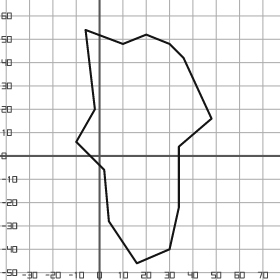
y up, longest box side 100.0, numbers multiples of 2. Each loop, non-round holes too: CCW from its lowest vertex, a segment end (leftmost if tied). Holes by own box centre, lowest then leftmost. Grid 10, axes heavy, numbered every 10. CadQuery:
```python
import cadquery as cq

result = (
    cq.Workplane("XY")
    .moveTo(16.0, -46.0)
    .lineTo(30.0, -40.0)
    .lineTo(34.0, -22.0)
    .lineTo(34.0, 4.0)
    .lineTo(48.0, 16.0)
    .lineTo(36.0, 42.0)
    .lineTo(30.0, 48.0)
    .lineTo(20.0, 52.0)
    .lineTo(10.0, 48.0)
    .lineTo(-6.0, 54.0)
    .lineTo(-2.0, 20.0)
    .lineTo(-10.0, 6.0)
    .lineTo(2.0, -6.0)
    .lineTo(4.0, -28.0)
    .close()
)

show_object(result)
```